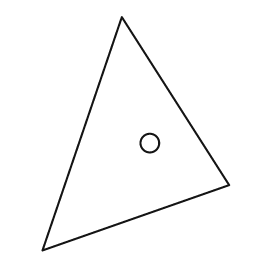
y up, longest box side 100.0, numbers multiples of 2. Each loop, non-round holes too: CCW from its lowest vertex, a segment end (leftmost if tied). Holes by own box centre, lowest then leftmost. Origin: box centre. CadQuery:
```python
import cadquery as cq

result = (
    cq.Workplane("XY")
    .moveTo(-40.0, -50.0)
    .lineTo(40.0, -22.0)
    .lineTo(-6.0, 50.0)
    .close()
    .moveTo(6.0, -4.0)
    .circle(4.0)
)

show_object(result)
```